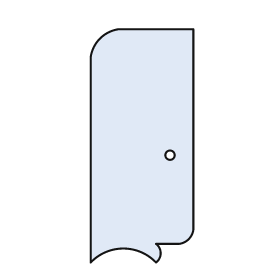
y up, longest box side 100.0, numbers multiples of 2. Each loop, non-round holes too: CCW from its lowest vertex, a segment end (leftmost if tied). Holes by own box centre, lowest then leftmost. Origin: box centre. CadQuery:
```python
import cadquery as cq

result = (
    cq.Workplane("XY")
    .moveTo(-22.0, -50.0)
    .threePointArc((-8.0, -44.0), (6.0, -50.0))
    .threePointArc((8.0, -46.0), (6.0, -42.0))
    .lineTo(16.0, -42.0)
    .threePointArc((20.0, -40.0), (22.0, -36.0))
    .lineTo(22.0, 50.0)
    .lineTo(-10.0, 50.0)
    .threePointArc((-18.0, 46.0), (-22.0, 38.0))
    .close()
    .moveTo(12.0, -4.0)
    .circle(2.0)
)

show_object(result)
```